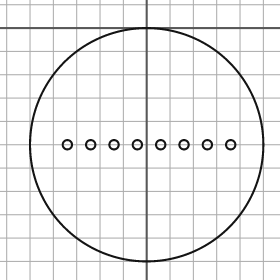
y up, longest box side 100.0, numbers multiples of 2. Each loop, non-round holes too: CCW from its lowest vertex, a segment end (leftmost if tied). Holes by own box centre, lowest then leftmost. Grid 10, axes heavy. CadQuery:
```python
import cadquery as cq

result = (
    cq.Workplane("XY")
    .moveTo(0.0, -50.0)
    .circle(50.0)
    .moveTo(-34.0, -50.0)
    .circle(2.0)
    .moveTo(-24.0, -50.0)
    .circle(2.0)
    .moveTo(-14.0, -50.0)
    .circle(2.0)
    .moveTo(-4.0, -50.0)
    .circle(2.0)
    .moveTo(6.0, -50.0)
    .circle(2.0)
    .moveTo(16.0, -50.0)
    .circle(2.0)
    .moveTo(26.0, -50.0)
    .circle(2.0)
    .moveTo(36.0, -50.0)
    .circle(2.0)
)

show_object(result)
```